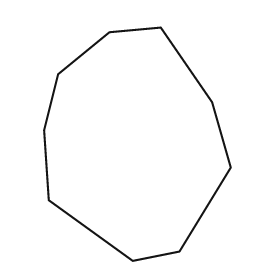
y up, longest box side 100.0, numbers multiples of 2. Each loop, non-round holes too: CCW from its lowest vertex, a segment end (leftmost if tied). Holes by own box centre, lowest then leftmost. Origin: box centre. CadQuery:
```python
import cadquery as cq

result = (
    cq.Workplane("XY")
    .moveTo(-2.0, -50.0)
    .lineTo(18.0, -46.0)
    .lineTo(40.0, -10.0)
    .lineTo(32.0, 18.0)
    .lineTo(10.0, 50.0)
    .lineTo(-12.0, 48.0)
    .lineTo(-34.0, 30.0)
    .lineTo(-40.0, 6.0)
    .lineTo(-38.0, -24.0)
    .close()
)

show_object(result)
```